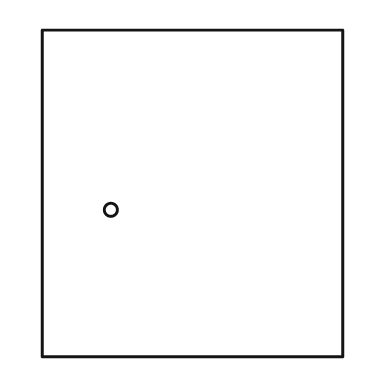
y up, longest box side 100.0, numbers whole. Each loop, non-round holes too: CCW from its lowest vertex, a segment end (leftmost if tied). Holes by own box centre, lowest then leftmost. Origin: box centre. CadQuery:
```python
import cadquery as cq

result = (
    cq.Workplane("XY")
    .moveTo(-46.0, -50.0)
    .lineTo(46.0, -50.0)
    .lineTo(46.0, 50.0)
    .lineTo(-46.0, 50.0)
    .close()
    .moveTo(-25.0, -5.0)
    .circle(2.0)
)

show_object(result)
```